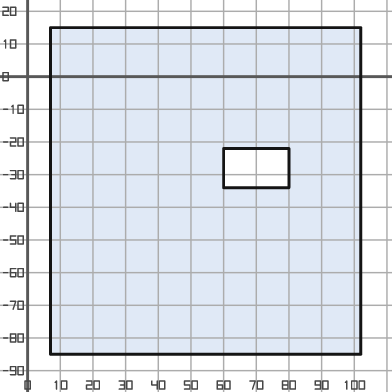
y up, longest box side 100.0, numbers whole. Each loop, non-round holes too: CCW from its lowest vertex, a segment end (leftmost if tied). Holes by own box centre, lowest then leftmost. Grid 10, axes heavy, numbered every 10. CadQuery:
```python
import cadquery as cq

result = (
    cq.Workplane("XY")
    .moveTo(7.0, -85.0)
    .lineTo(102.0, -85.0)
    .lineTo(102.0, 15.0)
    .lineTo(7.0, 15.0)
    .close()
    .moveTo(60.0, -34.0)
    .lineTo(80.0, -34.0)
    .lineTo(80.0, -22.0)
    .lineTo(60.0, -22.0)
    .close()
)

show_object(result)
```